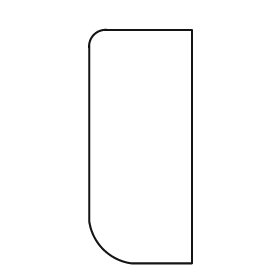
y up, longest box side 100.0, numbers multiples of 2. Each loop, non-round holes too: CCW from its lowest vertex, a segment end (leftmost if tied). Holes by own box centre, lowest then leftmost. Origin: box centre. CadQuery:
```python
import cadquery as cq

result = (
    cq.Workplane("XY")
    .moveTo(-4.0, -50.0)
    .lineTo(22.0, -50.0)
    .lineTo(22.0, 50.0)
    .lineTo(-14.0, 50.0)
    .threePointArc((-20.0, 48.0), (-22.0, 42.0))
    .lineTo(-22.0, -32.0)
    .threePointArc((-16.0, -44.0), (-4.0, -50.0))
    .close()
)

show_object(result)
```